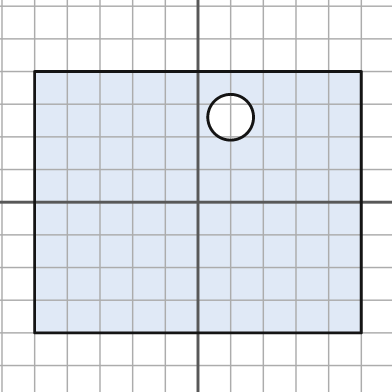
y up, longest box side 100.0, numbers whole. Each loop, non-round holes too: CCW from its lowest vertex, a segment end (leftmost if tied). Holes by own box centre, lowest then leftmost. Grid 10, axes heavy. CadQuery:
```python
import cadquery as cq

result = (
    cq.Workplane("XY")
    .moveTo(-50.0, -40.0)
    .lineTo(50.0, -40.0)
    .lineTo(50.0, 40.0)
    .lineTo(-50.0, 40.0)
    .close()
    .moveTo(10.0, 26.0)
    .circle(7.0)
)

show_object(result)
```